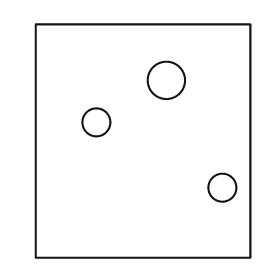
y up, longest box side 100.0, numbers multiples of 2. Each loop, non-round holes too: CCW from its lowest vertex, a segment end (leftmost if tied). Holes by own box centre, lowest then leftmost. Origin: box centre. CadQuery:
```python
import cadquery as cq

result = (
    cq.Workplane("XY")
    .moveTo(-46.0, -50.0)
    .lineTo(46.0, -50.0)
    .lineTo(46.0, 50.0)
    .lineTo(-46.0, 50.0)
    .close()
    .moveTo(34.0, -20.0)
    .circle(6.0)
    .moveTo(-20.0, 8.0)
    .circle(6.0)
    .moveTo(10.0, 26.0)
    .circle(8.0)
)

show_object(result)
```